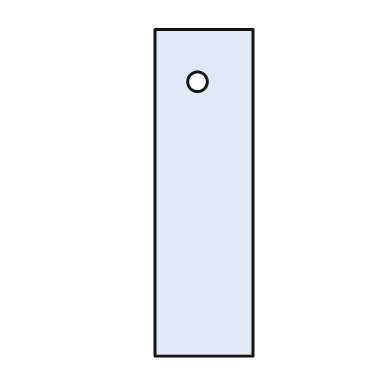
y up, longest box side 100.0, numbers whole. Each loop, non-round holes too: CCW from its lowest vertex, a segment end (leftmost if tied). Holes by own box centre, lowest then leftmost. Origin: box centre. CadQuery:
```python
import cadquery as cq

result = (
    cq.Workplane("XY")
    .moveTo(-15.0, -50.0)
    .lineTo(15.0, -50.0)
    .lineTo(15.0, 50.0)
    .lineTo(-15.0, 50.0)
    .close()
    .moveTo(-2.0, 34.0)
    .circle(3.0)
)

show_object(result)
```